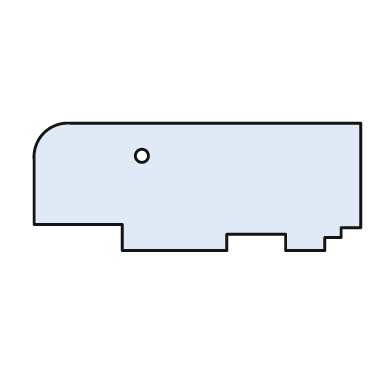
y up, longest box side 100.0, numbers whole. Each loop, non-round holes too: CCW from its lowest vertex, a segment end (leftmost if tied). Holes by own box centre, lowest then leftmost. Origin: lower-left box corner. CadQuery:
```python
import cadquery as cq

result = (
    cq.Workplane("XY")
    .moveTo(27.0, 0.0)
    .lineTo(59.0, 0.0)
    .lineTo(59.0, 5.0)
    .lineTo(77.0, 5.0)
    .lineTo(77.0, 0.0)
    .lineTo(89.0, 0.0)
    .lineTo(89.0, 4.0)
    .lineTo(94.0, 4.0)
    .lineTo(94.0, 7.0)
    .lineTo(100.0, 7.0)
    .lineTo(100.0, 39.0)
    .lineTo(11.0, 39.0)
    .threePointArc((3.0, 36.0), (0.0, 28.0))
    .lineTo(0.0, 8.0)
    .lineTo(27.0, 8.0)
    .close()
    .moveTo(33.0, 29.0)
    .circle(2.0)
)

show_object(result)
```